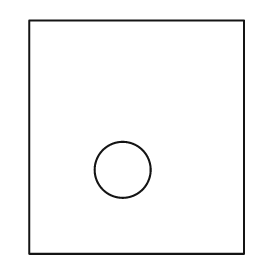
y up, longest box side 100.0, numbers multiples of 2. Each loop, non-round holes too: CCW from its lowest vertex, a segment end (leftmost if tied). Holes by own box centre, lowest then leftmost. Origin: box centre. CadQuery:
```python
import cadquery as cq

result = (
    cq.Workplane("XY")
    .moveTo(-46.0, -50.0)
    .lineTo(46.0, -50.0)
    .lineTo(46.0, 50.0)
    .lineTo(-46.0, 50.0)
    .close()
    .moveTo(-6.0, -14.0)
    .circle(12.0)
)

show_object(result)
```